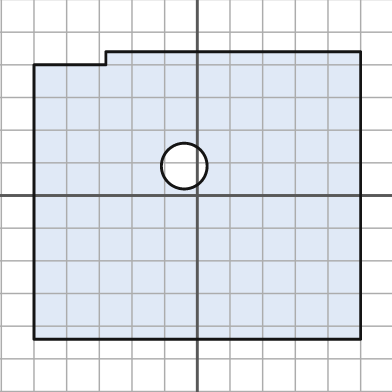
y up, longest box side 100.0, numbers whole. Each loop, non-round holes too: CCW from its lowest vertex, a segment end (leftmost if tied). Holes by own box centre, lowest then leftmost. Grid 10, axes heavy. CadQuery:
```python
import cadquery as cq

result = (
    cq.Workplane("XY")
    .moveTo(-50.0, -44.0)
    .lineTo(50.0, -44.0)
    .lineTo(50.0, 44.0)
    .lineTo(-28.0, 44.0)
    .lineTo(-28.0, 40.0)
    .lineTo(-50.0, 40.0)
    .close()
    .moveTo(-4.0, 9.0)
    .circle(7.0)
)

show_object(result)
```